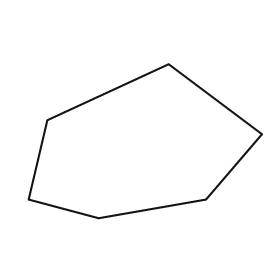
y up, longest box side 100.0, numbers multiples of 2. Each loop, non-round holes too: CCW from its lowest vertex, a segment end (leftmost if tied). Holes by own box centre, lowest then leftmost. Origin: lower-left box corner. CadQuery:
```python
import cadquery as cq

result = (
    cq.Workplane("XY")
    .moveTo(30.0, 0.0)
    .lineTo(76.0, 8.0)
    .lineTo(100.0, 36.0)
    .lineTo(60.0, 66.0)
    .lineTo(8.0, 42.0)
    .lineTo(0.0, 8.0)
    .close()
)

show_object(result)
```